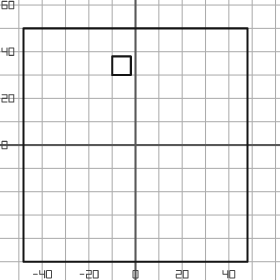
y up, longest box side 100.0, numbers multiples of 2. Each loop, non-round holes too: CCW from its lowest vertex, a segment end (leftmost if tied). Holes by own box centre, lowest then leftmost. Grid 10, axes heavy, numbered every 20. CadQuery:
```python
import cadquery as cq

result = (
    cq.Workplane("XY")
    .moveTo(-48.0, -50.0)
    .lineTo(48.0, -50.0)
    .lineTo(48.0, 50.0)
    .lineTo(-48.0, 50.0)
    .close()
    .moveTo(-10.0, 30.0)
    .lineTo(-2.0, 30.0)
    .lineTo(-2.0, 38.0)
    .lineTo(-10.0, 38.0)
    .close()
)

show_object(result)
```